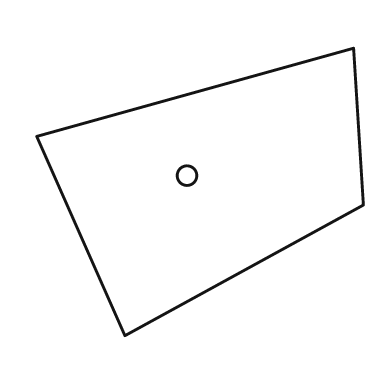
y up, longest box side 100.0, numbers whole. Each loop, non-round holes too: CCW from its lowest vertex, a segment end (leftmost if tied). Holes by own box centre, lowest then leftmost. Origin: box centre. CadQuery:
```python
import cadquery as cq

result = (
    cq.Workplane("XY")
    .moveTo(-23.0, -44.0)
    .lineTo(50.0, -4.0)
    .lineTo(47.0, 44.0)
    .lineTo(-50.0, 17.0)
    .close()
    .moveTo(-4.0, 5.0)
    .circle(3.0)
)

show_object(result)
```